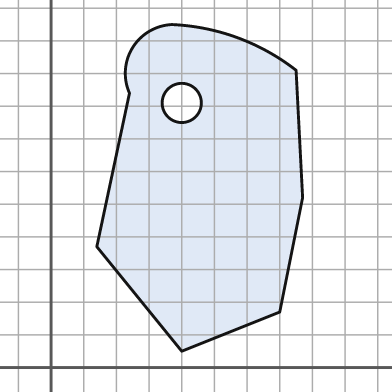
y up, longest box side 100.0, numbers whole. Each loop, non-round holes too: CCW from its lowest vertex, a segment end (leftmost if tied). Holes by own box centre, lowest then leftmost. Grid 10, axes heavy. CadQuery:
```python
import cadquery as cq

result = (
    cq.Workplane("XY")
    .moveTo(40.0, 5.0)
    .lineTo(70.0, 17.0)
    .lineTo(77.0, 52.0)
    .lineTo(75.0, 91.0)
    .threePointArc((57.0, 101.0), (37.0, 105.0))
    .threePointArc((25.0, 98.0), (24.0, 84.0))
    .lineTo(14.0, 37.0)
    .close()
    .moveTo(40.0, 81.0)
    .circle(6.0)
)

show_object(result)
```